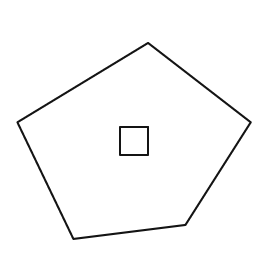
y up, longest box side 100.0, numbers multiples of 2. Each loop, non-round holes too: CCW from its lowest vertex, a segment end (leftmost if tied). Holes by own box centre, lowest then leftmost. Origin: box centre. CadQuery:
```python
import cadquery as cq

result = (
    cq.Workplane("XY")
    .moveTo(-26.0, -42.0)
    .lineTo(22.0, -36.0)
    .lineTo(50.0, 8.0)
    .lineTo(6.0, 42.0)
    .lineTo(-50.0, 8.0)
    .close()
    .moveTo(-6.0, -6.0)
    .lineTo(6.0, -6.0)
    .lineTo(6.0, 6.0)
    .lineTo(-6.0, 6.0)
    .close()
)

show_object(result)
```